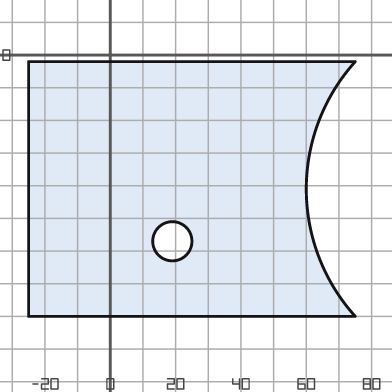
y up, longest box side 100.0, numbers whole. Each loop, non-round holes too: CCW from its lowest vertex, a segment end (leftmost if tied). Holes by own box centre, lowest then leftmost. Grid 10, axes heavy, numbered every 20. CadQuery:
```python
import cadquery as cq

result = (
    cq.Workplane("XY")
    .moveTo(-25.0, -80.0)
    .lineTo(75.0, -80.0)
    .threePointArc((60.0, -41.0), (75.0, -2.0))
    .lineTo(-25.0, -2.0)
    .close()
    .moveTo(19.0, -57.0)
    .circle(6.0)
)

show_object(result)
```